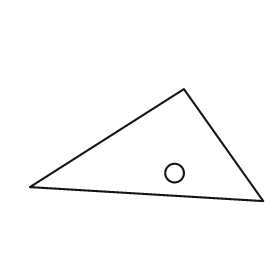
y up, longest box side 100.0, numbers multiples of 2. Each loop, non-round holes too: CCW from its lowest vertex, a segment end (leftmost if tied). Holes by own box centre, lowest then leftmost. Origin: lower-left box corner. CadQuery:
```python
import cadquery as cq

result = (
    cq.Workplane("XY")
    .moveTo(100.0, 0.0)
    .lineTo(66.0, 48.0)
    .lineTo(0.0, 6.0)
    .close()
    .moveTo(62.0, 12.0)
    .circle(4.0)
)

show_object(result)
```